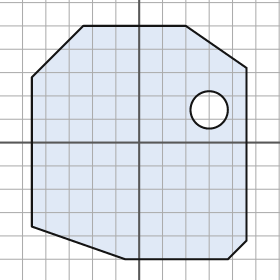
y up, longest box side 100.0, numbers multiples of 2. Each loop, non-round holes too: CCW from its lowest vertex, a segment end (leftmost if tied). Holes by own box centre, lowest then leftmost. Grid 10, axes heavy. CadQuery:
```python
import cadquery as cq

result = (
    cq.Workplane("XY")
    .moveTo(-6.0, -50.0)
    .lineTo(38.0, -50.0)
    .lineTo(46.0, -42.0)
    .lineTo(46.0, 32.0)
    .lineTo(20.0, 50.0)
    .lineTo(-24.0, 50.0)
    .lineTo(-46.0, 28.0)
    .lineTo(-46.0, -36.0)
    .close()
    .moveTo(30.0, 14.0)
    .circle(8.0)
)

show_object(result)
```